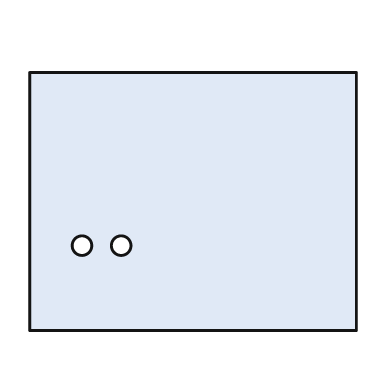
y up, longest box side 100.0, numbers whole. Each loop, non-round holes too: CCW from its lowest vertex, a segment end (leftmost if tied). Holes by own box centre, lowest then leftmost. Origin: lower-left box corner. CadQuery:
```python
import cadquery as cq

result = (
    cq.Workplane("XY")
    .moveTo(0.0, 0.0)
    .lineTo(100.0, 0.0)
    .lineTo(100.0, 79.0)
    .lineTo(0.0, 79.0)
    .close()
    .moveTo(16.0, 26.0)
    .circle(3.0)
    .moveTo(28.0, 26.0)
    .circle(3.0)
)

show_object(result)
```